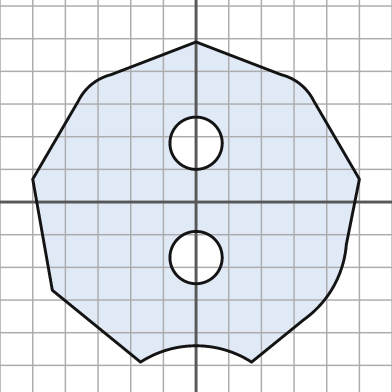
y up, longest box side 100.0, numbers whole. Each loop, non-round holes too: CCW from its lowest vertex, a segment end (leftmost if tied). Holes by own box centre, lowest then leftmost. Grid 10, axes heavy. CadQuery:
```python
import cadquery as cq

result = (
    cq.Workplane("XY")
    .moveTo(-17.0, -49.0)
    .threePointArc((0.0, -44.0), (17.0, -49.0))
    .lineTo(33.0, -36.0)
    .threePointArc((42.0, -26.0), (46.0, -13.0))
    .lineTo(50.0, 7.0)
    .lineTo(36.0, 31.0)
    .threePointArc((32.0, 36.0), (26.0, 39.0))
    .lineTo(0.0, 49.0)
    .lineTo(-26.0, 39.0)
    .threePointArc((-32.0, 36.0), (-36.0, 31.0))
    .lineTo(-50.0, 7.0)
    .lineTo(-44.0, -27.0)
    .close()
    .moveTo(0.0, -17.0)
    .circle(8.0)
    .moveTo(0.0, 18.0)
    .circle(8.0)
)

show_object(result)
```